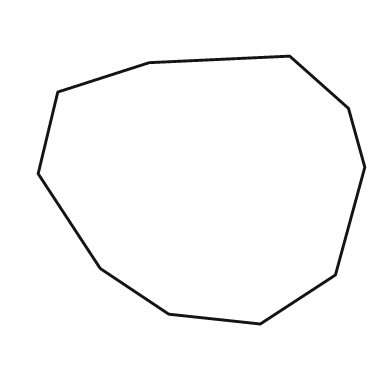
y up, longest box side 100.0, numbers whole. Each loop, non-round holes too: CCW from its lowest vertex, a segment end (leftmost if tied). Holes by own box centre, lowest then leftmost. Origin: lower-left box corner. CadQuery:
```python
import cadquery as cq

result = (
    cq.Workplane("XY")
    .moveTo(68.0, 0.0)
    .lineTo(91.0, 15.0)
    .lineTo(100.0, 48.0)
    .lineTo(95.0, 66.0)
    .lineTo(77.0, 82.0)
    .lineTo(34.0, 80.0)
    .lineTo(6.0, 71.0)
    .lineTo(0.0, 46.0)
    .lineTo(19.0, 17.0)
    .lineTo(40.0, 3.0)
    .close()
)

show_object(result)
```